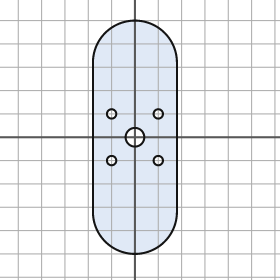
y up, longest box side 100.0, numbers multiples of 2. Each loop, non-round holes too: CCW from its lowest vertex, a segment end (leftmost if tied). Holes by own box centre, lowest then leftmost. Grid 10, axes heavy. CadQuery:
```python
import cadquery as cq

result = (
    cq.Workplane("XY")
    .moveTo(-18.0, -32.0)
    .threePointArc((0.0, -50.0), (18.0, -32.0))
    .lineTo(18.0, 32.0)
    .threePointArc((0.0, 50.0), (-18.0, 32.0))
    .close()
    .moveTo(-10.0, -10.0)
    .circle(2.0)
    .moveTo(10.0, -10.0)
    .circle(2.0)
    .moveTo(0.0, 0.0)
    .circle(4.0)
    .moveTo(-10.0, 10.0)
    .circle(2.0)
    .moveTo(10.0, 10.0)
    .circle(2.0)
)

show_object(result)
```